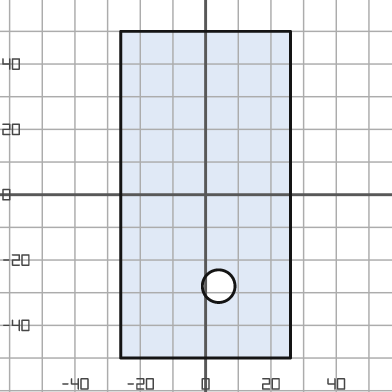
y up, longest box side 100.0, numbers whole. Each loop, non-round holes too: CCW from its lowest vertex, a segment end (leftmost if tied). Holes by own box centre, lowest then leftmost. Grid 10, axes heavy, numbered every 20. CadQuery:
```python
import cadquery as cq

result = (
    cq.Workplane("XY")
    .moveTo(-26.0, -50.0)
    .lineTo(26.0, -50.0)
    .lineTo(26.0, 50.0)
    .lineTo(-26.0, 50.0)
    .close()
    .moveTo(4.0, -28.0)
    .circle(5.0)
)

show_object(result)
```